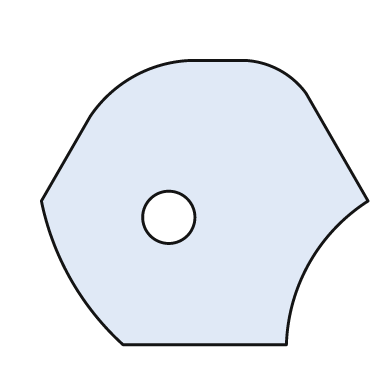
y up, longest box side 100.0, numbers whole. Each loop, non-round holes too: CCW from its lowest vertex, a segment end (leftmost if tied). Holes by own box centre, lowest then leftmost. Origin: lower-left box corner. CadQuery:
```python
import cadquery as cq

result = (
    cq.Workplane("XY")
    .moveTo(25.0, 0.0)
    .lineTo(75.0, 0.0)
    .threePointArc((82.0, 25.0), (100.0, 44.0))
    .lineTo(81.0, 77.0)
    .threePointArc((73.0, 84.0), (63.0, 87.0))
    .lineTo(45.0, 87.0)
    .threePointArc((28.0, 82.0), (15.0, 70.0))
    .lineTo(0.0, 44.0)
    .threePointArc((9.0, 20.0), (25.0, 0.0))
    .close()
    .moveTo(39.0, 39.0)
    .circle(8.0)
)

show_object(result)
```